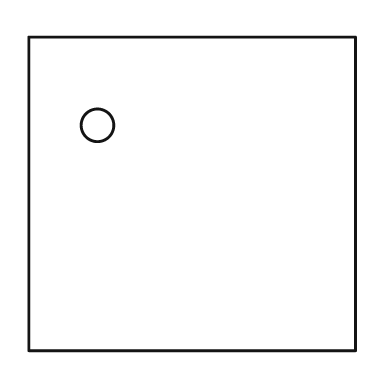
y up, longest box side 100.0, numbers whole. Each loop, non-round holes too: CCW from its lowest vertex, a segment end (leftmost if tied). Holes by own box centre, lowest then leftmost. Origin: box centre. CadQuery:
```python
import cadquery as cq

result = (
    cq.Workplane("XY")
    .moveTo(-50.0, -48.0)
    .lineTo(50.0, -48.0)
    .lineTo(50.0, 48.0)
    .lineTo(-50.0, 48.0)
    .close()
    .moveTo(-29.0, 21.0)
    .circle(5.0)
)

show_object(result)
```